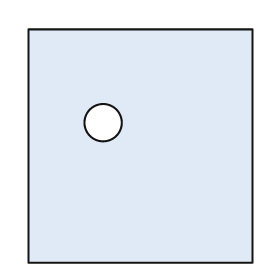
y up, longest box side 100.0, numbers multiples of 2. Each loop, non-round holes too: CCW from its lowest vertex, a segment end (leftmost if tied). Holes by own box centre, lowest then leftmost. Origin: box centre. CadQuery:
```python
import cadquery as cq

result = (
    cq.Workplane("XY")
    .moveTo(-48.0, -50.0)
    .lineTo(48.0, -50.0)
    .lineTo(48.0, 50.0)
    .lineTo(-48.0, 50.0)
    .close()
    .moveTo(-16.0, 10.0)
    .circle(8.0)
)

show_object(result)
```